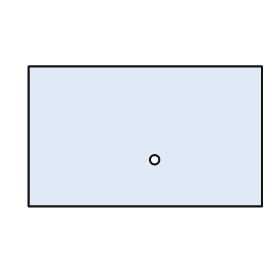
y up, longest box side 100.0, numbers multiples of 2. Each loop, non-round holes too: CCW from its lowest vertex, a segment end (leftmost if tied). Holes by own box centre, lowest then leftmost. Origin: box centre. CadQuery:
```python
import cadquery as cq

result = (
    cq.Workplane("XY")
    .moveTo(-50.0, -30.0)
    .lineTo(50.0, -30.0)
    .lineTo(50.0, 30.0)
    .lineTo(-50.0, 30.0)
    .close()
    .moveTo(4.0, -10.0)
    .circle(2.0)
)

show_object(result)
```